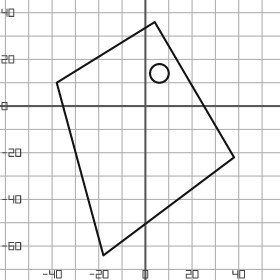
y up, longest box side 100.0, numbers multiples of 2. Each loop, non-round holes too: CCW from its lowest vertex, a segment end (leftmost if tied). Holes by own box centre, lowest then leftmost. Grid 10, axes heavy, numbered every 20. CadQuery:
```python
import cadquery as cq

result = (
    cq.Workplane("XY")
    .moveTo(-18.0, -64.0)
    .lineTo(38.0, -22.0)
    .lineTo(4.0, 36.0)
    .lineTo(-38.0, 10.0)
    .close()
    .moveTo(6.0, 14.0)
    .circle(4.0)
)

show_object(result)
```